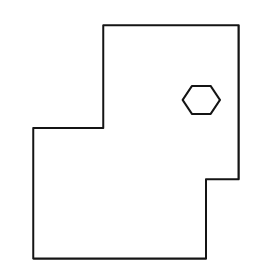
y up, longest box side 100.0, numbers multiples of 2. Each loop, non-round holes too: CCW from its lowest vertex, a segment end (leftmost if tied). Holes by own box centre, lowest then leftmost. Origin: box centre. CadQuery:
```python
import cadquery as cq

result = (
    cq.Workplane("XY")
    .moveTo(-44.0, -50.0)
    .lineTo(30.0, -50.0)
    .lineTo(30.0, -16.0)
    .lineTo(44.0, -16.0)
    .lineTo(44.0, 50.0)
    .lineTo(-14.0, 50.0)
    .lineTo(-14.0, 6.0)
    .lineTo(-44.0, 6.0)
    .close()
    .moveTo(24.0, 12.0)
    .lineTo(32.0, 12.0)
    .lineTo(36.0, 18.0)
    .lineTo(32.0, 24.0)
    .lineTo(24.0, 24.0)
    .lineTo(20.0, 18.0)
    .close()
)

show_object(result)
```